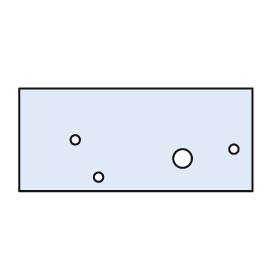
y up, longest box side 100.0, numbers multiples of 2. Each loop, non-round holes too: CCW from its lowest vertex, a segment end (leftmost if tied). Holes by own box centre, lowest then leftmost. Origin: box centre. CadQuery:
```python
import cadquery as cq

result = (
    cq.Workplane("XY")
    .moveTo(-50.0, -22.0)
    .lineTo(50.0, -22.0)
    .lineTo(50.0, 22.0)
    .lineTo(-50.0, 22.0)
    .close()
    .moveTo(-16.0, -16.0)
    .circle(2.0)
    .moveTo(20.0, -8.0)
    .circle(4.0)
    .moveTo(42.0, -4.0)
    .circle(2.0)
    .moveTo(-26.0, 0.0)
    .circle(2.0)
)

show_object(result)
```